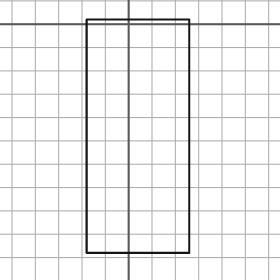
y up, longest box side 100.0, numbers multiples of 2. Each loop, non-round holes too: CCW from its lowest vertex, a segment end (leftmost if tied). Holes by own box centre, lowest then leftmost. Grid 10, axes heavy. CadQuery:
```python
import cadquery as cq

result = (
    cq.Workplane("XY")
    .moveTo(-18.0, -98.0)
    .lineTo(26.0, -98.0)
    .lineTo(26.0, 2.0)
    .lineTo(-18.0, 2.0)
    .close()
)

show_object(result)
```